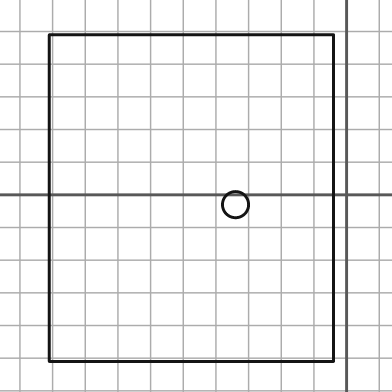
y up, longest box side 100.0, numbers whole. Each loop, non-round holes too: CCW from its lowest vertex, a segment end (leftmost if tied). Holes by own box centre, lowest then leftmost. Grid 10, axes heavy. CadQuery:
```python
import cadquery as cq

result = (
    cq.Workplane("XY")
    .moveTo(-91.0, -51.0)
    .lineTo(-4.0, -51.0)
    .lineTo(-4.0, 49.0)
    .lineTo(-91.0, 49.0)
    .close()
    .moveTo(-34.0, -3.0)
    .circle(4.0)
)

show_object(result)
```